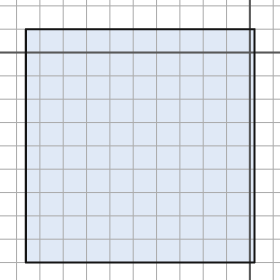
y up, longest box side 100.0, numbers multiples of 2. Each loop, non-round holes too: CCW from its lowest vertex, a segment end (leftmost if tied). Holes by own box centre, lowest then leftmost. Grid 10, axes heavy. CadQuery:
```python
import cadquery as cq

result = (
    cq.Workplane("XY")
    .moveTo(-96.0, -90.0)
    .lineTo(2.0, -90.0)
    .lineTo(2.0, 10.0)
    .lineTo(-96.0, 10.0)
    .close()
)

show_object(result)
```